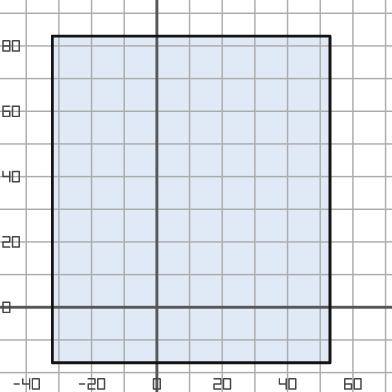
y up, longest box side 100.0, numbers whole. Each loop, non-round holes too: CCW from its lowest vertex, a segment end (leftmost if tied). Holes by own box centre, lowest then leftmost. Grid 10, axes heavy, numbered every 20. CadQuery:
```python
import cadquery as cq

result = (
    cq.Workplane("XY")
    .moveTo(-32.0, -17.0)
    .lineTo(53.0, -17.0)
    .lineTo(53.0, 83.0)
    .lineTo(-32.0, 83.0)
    .close()
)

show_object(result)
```